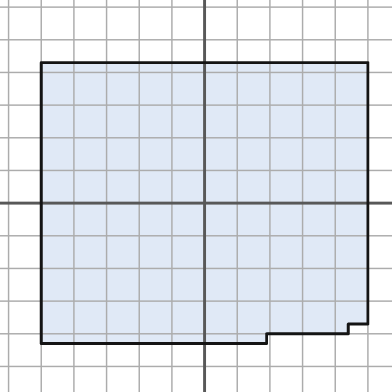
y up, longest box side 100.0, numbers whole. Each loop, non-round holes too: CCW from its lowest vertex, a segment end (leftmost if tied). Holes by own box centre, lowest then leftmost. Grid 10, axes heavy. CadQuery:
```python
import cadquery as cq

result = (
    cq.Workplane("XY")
    .moveTo(-50.0, -43.0)
    .lineTo(19.0, -43.0)
    .lineTo(19.0, -40.0)
    .lineTo(44.0, -40.0)
    .lineTo(44.0, -37.0)
    .lineTo(50.0, -37.0)
    .lineTo(50.0, 43.0)
    .lineTo(-50.0, 43.0)
    .close()
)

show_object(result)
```